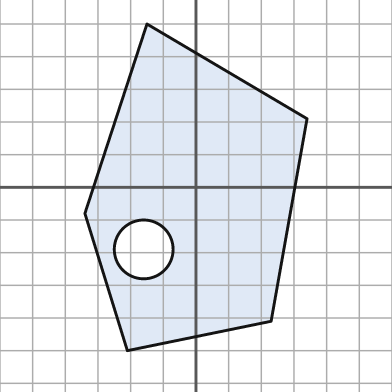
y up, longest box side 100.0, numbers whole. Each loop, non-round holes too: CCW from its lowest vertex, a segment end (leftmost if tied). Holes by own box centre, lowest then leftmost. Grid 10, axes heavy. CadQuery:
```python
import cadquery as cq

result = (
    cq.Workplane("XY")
    .moveTo(-21.0, -50.0)
    .lineTo(23.0, -41.0)
    .lineTo(34.0, 21.0)
    .lineTo(-15.0, 50.0)
    .lineTo(-34.0, -8.0)
    .close()
    .moveTo(-16.0, -19.0)
    .circle(9.0)
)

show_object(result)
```